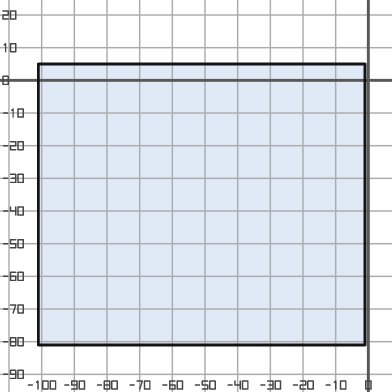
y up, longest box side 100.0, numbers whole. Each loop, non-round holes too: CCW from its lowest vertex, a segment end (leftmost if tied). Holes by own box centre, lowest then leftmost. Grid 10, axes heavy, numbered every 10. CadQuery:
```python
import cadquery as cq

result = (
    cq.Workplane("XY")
    .moveTo(-101.0, -81.0)
    .lineTo(-1.0, -81.0)
    .lineTo(-1.0, 5.0)
    .lineTo(-101.0, 5.0)
    .close()
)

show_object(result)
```